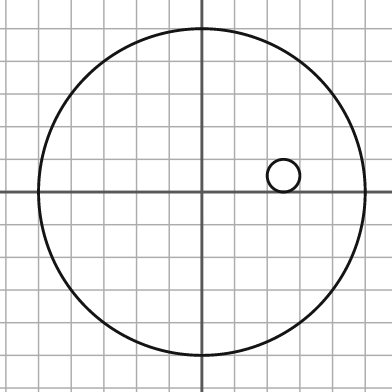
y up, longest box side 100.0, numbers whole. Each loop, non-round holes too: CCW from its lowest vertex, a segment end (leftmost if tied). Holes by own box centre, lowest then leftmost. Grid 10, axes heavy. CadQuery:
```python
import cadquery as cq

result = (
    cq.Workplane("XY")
    .moveTo(0.0, 0.0)
    .circle(50.0)
    .moveTo(25.0, 5.0)
    .circle(5.0)
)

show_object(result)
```